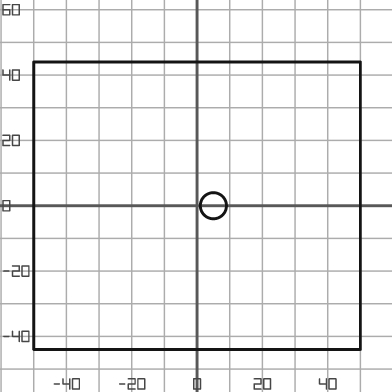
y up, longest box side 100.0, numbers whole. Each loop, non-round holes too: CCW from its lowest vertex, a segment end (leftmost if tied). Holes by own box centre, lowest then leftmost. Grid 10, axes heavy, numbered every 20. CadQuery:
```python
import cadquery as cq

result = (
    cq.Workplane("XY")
    .moveTo(-50.0, -44.0)
    .lineTo(50.0, -44.0)
    .lineTo(50.0, 44.0)
    .lineTo(-50.0, 44.0)
    .close()
    .moveTo(5.0, 0.0)
    .circle(4.0)
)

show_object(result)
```